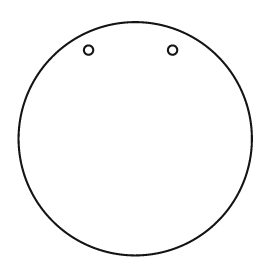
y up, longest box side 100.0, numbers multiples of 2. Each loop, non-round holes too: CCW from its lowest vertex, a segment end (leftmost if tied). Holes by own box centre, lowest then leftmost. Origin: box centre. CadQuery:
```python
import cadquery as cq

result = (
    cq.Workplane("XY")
    .moveTo(0.0, 0.0)
    .circle(50.0)
    .moveTo(-20.0, 38.0)
    .circle(2.0)
    .moveTo(16.0, 38.0)
    .circle(2.0)
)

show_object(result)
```